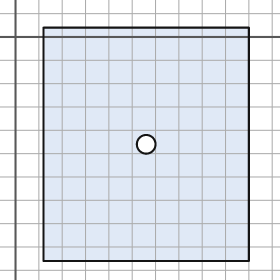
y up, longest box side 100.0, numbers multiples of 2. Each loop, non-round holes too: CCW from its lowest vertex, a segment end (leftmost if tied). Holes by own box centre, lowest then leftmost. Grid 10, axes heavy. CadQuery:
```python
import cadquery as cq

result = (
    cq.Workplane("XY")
    .moveTo(12.0, -96.0)
    .lineTo(100.0, -96.0)
    .lineTo(100.0, 4.0)
    .lineTo(12.0, 4.0)
    .close()
    .moveTo(56.0, -46.0)
    .circle(4.0)
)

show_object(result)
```